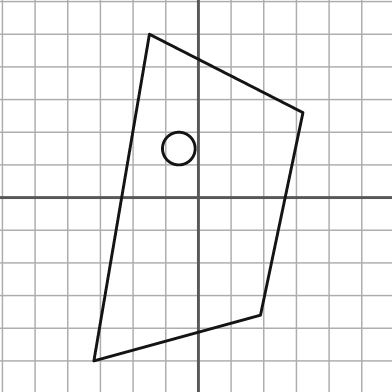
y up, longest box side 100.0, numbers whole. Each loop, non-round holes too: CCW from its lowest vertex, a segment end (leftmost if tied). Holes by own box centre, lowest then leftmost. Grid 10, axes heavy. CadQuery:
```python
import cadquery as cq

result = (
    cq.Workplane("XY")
    .moveTo(-32.0, -50.0)
    .lineTo(19.0, -36.0)
    .lineTo(32.0, 26.0)
    .lineTo(-15.0, 50.0)
    .close()
    .moveTo(-6.0, 15.0)
    .circle(5.0)
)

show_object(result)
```